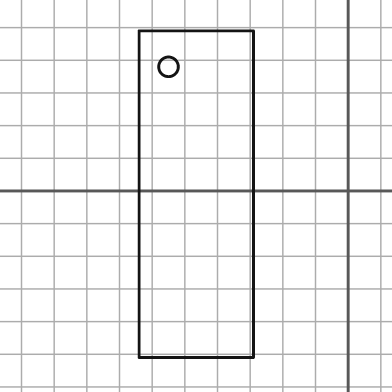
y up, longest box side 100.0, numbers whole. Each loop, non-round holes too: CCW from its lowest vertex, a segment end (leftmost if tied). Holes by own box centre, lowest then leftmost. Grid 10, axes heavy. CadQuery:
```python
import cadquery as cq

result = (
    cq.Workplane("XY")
    .moveTo(-64.0, -51.0)
    .lineTo(-29.0, -51.0)
    .lineTo(-29.0, 49.0)
    .lineTo(-64.0, 49.0)
    .close()
    .moveTo(-55.0, 38.0)
    .circle(3.0)
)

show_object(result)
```